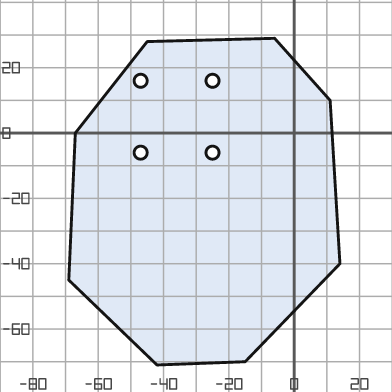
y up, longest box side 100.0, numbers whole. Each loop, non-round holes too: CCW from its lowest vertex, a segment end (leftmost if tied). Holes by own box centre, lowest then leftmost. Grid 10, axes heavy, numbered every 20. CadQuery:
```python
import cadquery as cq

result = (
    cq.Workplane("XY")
    .moveTo(-42.0, -71.0)
    .lineTo(-15.0, -70.0)
    .lineTo(14.0, -40.0)
    .lineTo(11.0, 10.0)
    .lineTo(-6.0, 29.0)
    .lineTo(-45.0, 28.0)
    .lineTo(-67.0, 0.0)
    .lineTo(-69.0, -45.0)
    .close()
    .moveTo(-47.0, -6.0)
    .circle(2.0)
    .moveTo(-25.0, -6.0)
    .circle(2.0)
    .moveTo(-47.0, 16.0)
    .circle(2.0)
    .moveTo(-25.0, 16.0)
    .circle(2.0)
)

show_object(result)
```